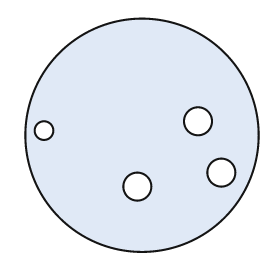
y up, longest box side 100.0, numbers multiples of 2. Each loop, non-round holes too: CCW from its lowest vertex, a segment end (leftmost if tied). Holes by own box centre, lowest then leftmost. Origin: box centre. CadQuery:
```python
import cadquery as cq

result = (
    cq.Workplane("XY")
    .moveTo(0.0, 0.0)
    .circle(50.0)
    .moveTo(-2.0, -22.0)
    .circle(6.0)
    .moveTo(34.0, -16.0)
    .circle(6.0)
    .moveTo(-42.0, 2.0)
    .circle(4.0)
    .moveTo(24.0, 6.0)
    .circle(6.0)
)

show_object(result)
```